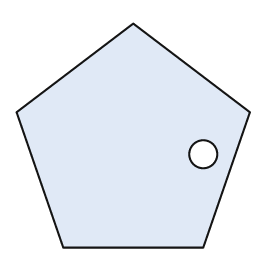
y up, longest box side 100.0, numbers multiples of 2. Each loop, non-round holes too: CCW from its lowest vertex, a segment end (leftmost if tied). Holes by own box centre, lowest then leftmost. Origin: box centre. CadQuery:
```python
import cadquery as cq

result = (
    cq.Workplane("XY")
    .moveTo(-30.0, -48.0)
    .lineTo(30.0, -48.0)
    .lineTo(50.0, 10.0)
    .lineTo(0.0, 48.0)
    .lineTo(-50.0, 10.0)
    .close()
    .moveTo(30.0, -8.0)
    .circle(6.0)
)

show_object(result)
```